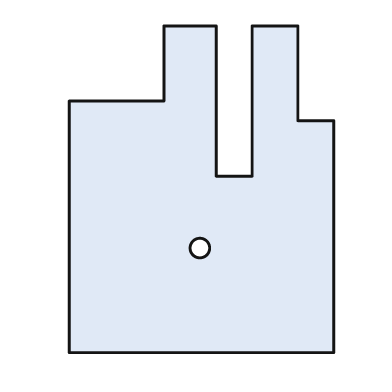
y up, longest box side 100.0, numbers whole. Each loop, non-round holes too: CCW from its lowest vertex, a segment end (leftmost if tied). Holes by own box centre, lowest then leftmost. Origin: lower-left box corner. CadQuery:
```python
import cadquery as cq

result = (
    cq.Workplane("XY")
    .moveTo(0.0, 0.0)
    .lineTo(81.0, 0.0)
    .lineTo(81.0, 71.0)
    .lineTo(70.0, 71.0)
    .lineTo(70.0, 100.0)
    .lineTo(56.0, 100.0)
    .lineTo(56.0, 54.0)
    .lineTo(45.0, 54.0)
    .lineTo(45.0, 100.0)
    .lineTo(29.0, 100.0)
    .lineTo(29.0, 77.0)
    .lineTo(0.0, 77.0)
    .close()
    .moveTo(40.0, 32.0)
    .circle(3.0)
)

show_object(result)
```